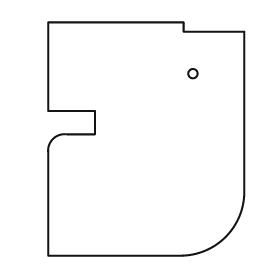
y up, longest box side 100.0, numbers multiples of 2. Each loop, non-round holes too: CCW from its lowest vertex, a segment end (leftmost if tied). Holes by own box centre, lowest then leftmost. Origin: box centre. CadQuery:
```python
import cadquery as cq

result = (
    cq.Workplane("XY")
    .moveTo(-42.0, -50.0)
    .lineTo(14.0, -50.0)
    .threePointArc((34.0, -42.0), (42.0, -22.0))
    .lineTo(42.0, 46.0)
    .lineTo(16.0, 46.0)
    .lineTo(16.0, 50.0)
    .lineTo(-42.0, 50.0)
    .lineTo(-42.0, 12.0)
    .lineTo(-22.0, 12.0)
    .lineTo(-22.0, 2.0)
    .lineTo(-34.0, 2.0)
    .threePointArc((-40.0, 0.0), (-42.0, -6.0))
    .close()
    .moveTo(20.0, 28.0)
    .circle(2.0)
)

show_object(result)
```